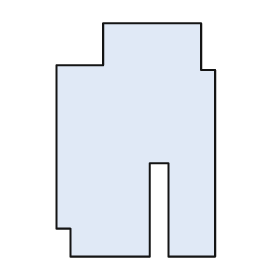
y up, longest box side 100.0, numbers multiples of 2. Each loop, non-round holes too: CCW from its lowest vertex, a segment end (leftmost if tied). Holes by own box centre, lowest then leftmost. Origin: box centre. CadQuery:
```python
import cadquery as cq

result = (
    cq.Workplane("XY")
    .moveTo(-28.0, -50.0)
    .lineTo(6.0, -50.0)
    .lineTo(6.0, -10.0)
    .lineTo(14.0, -10.0)
    .lineTo(14.0, -50.0)
    .lineTo(34.0, -50.0)
    .lineTo(34.0, 30.0)
    .lineTo(28.0, 30.0)
    .lineTo(28.0, 50.0)
    .lineTo(-14.0, 50.0)
    .lineTo(-14.0, 32.0)
    .lineTo(-34.0, 32.0)
    .lineTo(-34.0, -38.0)
    .lineTo(-28.0, -38.0)
    .close()
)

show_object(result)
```